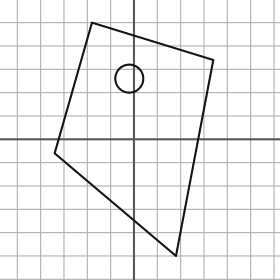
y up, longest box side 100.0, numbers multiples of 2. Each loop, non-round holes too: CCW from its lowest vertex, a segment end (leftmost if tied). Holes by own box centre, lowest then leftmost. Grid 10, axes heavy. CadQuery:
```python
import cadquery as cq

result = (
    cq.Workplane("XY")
    .moveTo(18.0, -50.0)
    .lineTo(34.0, 34.0)
    .lineTo(-18.0, 50.0)
    .lineTo(-34.0, -6.0)
    .close()
    .moveTo(-2.0, 26.0)
    .circle(6.0)
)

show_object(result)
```